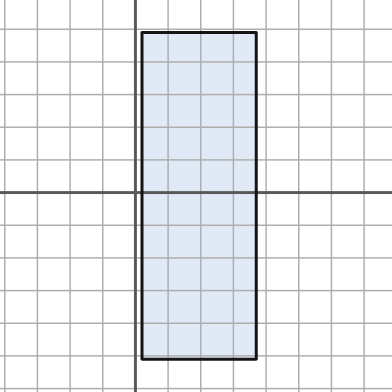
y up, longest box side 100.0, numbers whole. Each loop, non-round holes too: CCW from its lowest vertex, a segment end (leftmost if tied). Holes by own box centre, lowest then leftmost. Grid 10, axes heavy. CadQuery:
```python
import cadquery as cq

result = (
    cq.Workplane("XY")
    .moveTo(2.0, -51.0)
    .lineTo(37.0, -51.0)
    .lineTo(37.0, 49.0)
    .lineTo(2.0, 49.0)
    .close()
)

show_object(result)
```